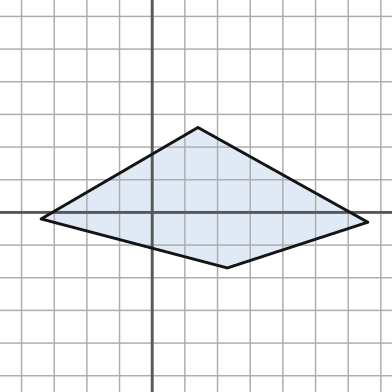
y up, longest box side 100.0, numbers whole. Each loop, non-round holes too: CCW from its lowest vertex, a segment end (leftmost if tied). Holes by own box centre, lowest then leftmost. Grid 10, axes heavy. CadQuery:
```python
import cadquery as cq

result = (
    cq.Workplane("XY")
    .moveTo(23.0, -17.0)
    .lineTo(66.0, -3.0)
    .lineTo(14.0, 26.0)
    .lineTo(-34.0, -2.0)
    .close()
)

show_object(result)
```